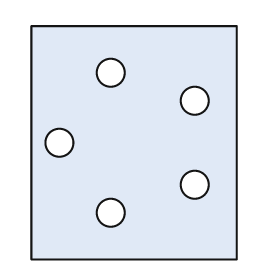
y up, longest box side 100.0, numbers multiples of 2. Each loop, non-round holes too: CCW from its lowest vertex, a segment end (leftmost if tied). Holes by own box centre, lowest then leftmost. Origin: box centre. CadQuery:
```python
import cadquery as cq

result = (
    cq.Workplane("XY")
    .moveTo(-44.0, -50.0)
    .lineTo(44.0, -50.0)
    .lineTo(44.0, 50.0)
    .lineTo(-44.0, 50.0)
    .close()
    .moveTo(-10.0, -30.0)
    .circle(6.0)
    .moveTo(26.0, -18.0)
    .circle(6.0)
    .moveTo(-32.0, 0.0)
    .circle(6.0)
    .moveTo(26.0, 18.0)
    .circle(6.0)
    .moveTo(-10.0, 30.0)
    .circle(6.0)
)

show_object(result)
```